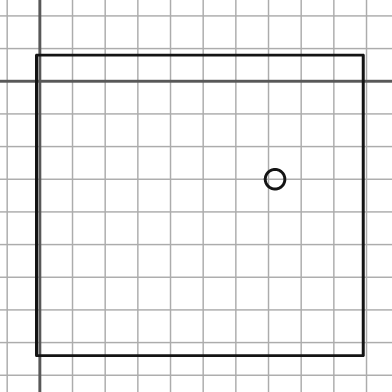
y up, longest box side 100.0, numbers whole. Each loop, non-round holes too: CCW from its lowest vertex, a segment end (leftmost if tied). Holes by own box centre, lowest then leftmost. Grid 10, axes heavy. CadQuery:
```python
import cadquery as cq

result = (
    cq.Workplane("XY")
    .moveTo(-1.0, -84.0)
    .lineTo(99.0, -84.0)
    .lineTo(99.0, 8.0)
    .lineTo(-1.0, 8.0)
    .close()
    .moveTo(72.0, -30.0)
    .circle(3.0)
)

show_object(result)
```